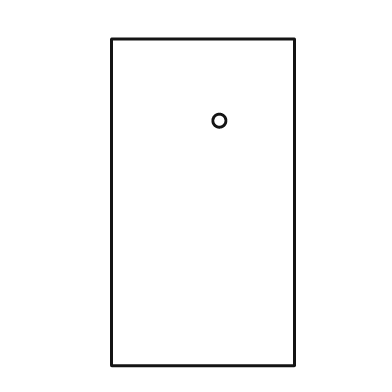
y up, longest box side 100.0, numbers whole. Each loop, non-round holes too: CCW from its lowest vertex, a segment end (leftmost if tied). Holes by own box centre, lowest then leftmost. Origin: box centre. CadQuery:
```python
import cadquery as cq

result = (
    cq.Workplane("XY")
    .moveTo(-28.0, -50.0)
    .lineTo(28.0, -50.0)
    .lineTo(28.0, 50.0)
    .lineTo(-28.0, 50.0)
    .close()
    .moveTo(5.0, 25.0)
    .circle(2.0)
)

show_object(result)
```